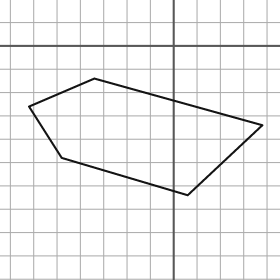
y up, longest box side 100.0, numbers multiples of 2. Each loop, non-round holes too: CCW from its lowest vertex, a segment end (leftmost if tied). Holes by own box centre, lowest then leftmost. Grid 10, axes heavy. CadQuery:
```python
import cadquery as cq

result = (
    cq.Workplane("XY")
    .moveTo(6.0, -64.0)
    .lineTo(38.0, -34.0)
    .lineTo(-34.0, -14.0)
    .lineTo(-62.0, -26.0)
    .lineTo(-48.0, -48.0)
    .close()
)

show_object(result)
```